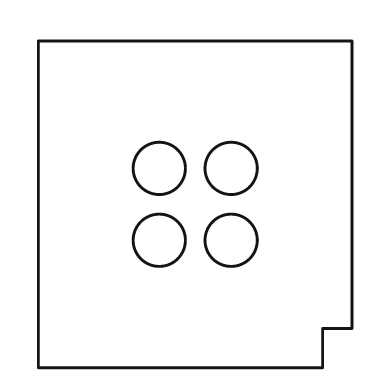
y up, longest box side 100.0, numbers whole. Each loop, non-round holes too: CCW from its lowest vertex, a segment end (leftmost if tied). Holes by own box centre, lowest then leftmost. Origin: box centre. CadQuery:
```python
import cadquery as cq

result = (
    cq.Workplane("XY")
    .moveTo(-48.0, -50.0)
    .lineTo(39.0, -50.0)
    .lineTo(39.0, -38.0)
    .lineTo(48.0, -38.0)
    .lineTo(48.0, 50.0)
    .lineTo(-48.0, 50.0)
    .close()
    .moveTo(-11.0, -11.0)
    .circle(8.0)
    .moveTo(11.0, -11.0)
    .circle(8.0)
    .moveTo(-11.0, 11.0)
    .circle(8.0)
    .moveTo(11.0, 11.0)
    .circle(8.0)
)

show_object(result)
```